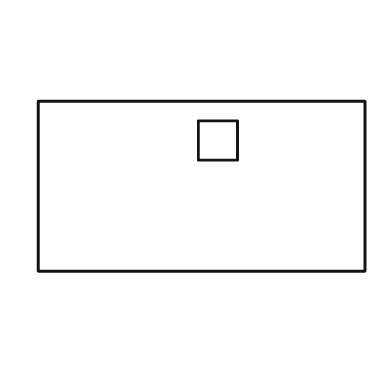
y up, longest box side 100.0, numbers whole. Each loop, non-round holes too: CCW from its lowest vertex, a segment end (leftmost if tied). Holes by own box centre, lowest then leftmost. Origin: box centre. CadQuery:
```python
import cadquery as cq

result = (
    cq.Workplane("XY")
    .moveTo(-50.0, -26.0)
    .lineTo(50.0, -26.0)
    .lineTo(50.0, 26.0)
    .lineTo(-50.0, 26.0)
    .close()
    .moveTo(-1.0, 8.0)
    .lineTo(11.0, 8.0)
    .lineTo(11.0, 20.0)
    .lineTo(-1.0, 20.0)
    .close()
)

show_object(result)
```